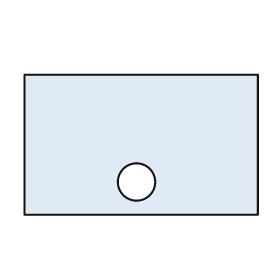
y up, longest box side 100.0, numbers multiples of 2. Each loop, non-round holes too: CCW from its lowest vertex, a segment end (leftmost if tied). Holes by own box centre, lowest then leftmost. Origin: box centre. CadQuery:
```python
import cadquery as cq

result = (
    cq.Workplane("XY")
    .moveTo(-50.0, -30.0)
    .lineTo(50.0, -30.0)
    .lineTo(50.0, 30.0)
    .lineTo(-50.0, 30.0)
    .close()
    .moveTo(-2.0, -16.0)
    .circle(8.0)
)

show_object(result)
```